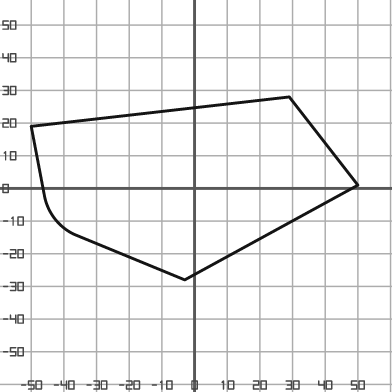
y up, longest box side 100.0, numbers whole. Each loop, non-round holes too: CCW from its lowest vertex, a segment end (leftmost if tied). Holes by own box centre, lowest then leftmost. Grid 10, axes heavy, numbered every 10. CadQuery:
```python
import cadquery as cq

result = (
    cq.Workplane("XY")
    .moveTo(-3.0, -28.0)
    .lineTo(50.0, 1.0)
    .lineTo(29.0, 28.0)
    .lineTo(-50.0, 19.0)
    .lineTo(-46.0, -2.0)
    .threePointArc((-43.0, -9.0), (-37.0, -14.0))
    .close()
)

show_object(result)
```